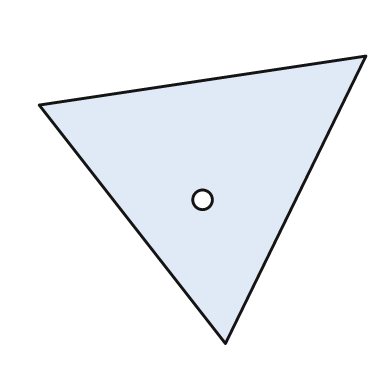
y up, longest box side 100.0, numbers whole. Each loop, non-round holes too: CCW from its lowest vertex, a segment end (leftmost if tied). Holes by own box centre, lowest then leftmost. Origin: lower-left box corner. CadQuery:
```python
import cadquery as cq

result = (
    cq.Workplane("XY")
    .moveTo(57.0, 0.0)
    .lineTo(100.0, 88.0)
    .lineTo(0.0, 73.0)
    .close()
    .moveTo(50.0, 44.0)
    .circle(3.0)
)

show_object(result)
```